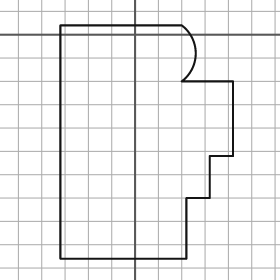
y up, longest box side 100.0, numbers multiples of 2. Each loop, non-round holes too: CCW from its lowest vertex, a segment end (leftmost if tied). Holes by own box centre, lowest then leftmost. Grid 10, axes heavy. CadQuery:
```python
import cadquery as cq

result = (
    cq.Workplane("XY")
    .moveTo(-32.0, -96.0)
    .lineTo(22.0, -96.0)
    .lineTo(22.0, -70.0)
    .lineTo(32.0, -70.0)
    .lineTo(32.0, -52.0)
    .lineTo(42.0, -52.0)
    .lineTo(42.0, -20.0)
    .lineTo(20.0, -20.0)
    .threePointArc((26.0, -8.0), (20.0, 4.0))
    .lineTo(-32.0, 4.0)
    .close()
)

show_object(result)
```